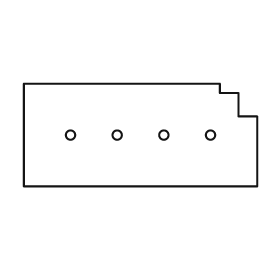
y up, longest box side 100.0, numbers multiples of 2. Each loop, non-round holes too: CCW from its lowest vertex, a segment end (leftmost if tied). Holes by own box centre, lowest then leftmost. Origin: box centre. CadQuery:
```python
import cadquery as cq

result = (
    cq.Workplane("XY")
    .moveTo(-50.0, -22.0)
    .lineTo(50.0, -22.0)
    .lineTo(50.0, 8.0)
    .lineTo(42.0, 8.0)
    .lineTo(42.0, 18.0)
    .lineTo(34.0, 18.0)
    .lineTo(34.0, 22.0)
    .lineTo(-50.0, 22.0)
    .close()
    .moveTo(-30.0, 0.0)
    .circle(2.0)
    .moveTo(-10.0, 0.0)
    .circle(2.0)
    .moveTo(10.0, 0.0)
    .circle(2.0)
    .moveTo(30.0, 0.0)
    .circle(2.0)
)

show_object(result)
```